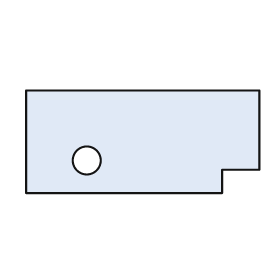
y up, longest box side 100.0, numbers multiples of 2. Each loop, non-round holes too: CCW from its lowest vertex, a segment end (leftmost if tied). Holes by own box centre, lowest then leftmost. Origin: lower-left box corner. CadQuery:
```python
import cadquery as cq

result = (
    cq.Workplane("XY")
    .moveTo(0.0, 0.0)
    .lineTo(84.0, 0.0)
    .lineTo(84.0, 10.0)
    .lineTo(100.0, 10.0)
    .lineTo(100.0, 44.0)
    .lineTo(0.0, 44.0)
    .close()
    .moveTo(26.0, 14.0)
    .circle(6.0)
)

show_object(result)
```